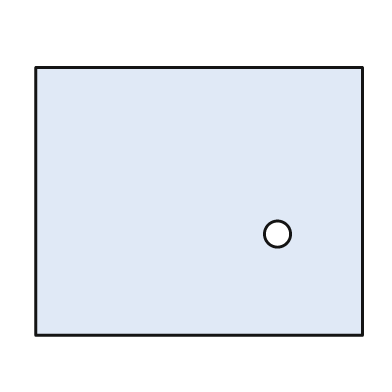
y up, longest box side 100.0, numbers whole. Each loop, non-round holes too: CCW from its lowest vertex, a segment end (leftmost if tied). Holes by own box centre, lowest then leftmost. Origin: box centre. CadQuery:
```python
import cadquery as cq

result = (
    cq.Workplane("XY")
    .moveTo(-50.0, -41.0)
    .lineTo(50.0, -41.0)
    .lineTo(50.0, 41.0)
    .lineTo(-50.0, 41.0)
    .close()
    .moveTo(24.0, -10.0)
    .circle(4.0)
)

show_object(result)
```